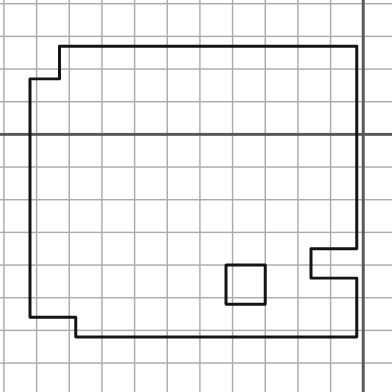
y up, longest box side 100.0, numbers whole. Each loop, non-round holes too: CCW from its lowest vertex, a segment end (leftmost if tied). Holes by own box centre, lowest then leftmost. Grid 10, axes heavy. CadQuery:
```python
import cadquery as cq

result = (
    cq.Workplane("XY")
    .moveTo(-88.0, -62.0)
    .lineTo(-2.0, -62.0)
    .lineTo(-2.0, -44.0)
    .lineTo(-16.0, -44.0)
    .lineTo(-16.0, -35.0)
    .lineTo(-2.0, -35.0)
    .lineTo(-2.0, 27.0)
    .lineTo(-93.0, 27.0)
    .lineTo(-93.0, 17.0)
    .lineTo(-102.0, 17.0)
    .lineTo(-102.0, -56.0)
    .lineTo(-88.0, -56.0)
    .close()
    .moveTo(-42.0, -52.0)
    .lineTo(-30.0, -52.0)
    .lineTo(-30.0, -40.0)
    .lineTo(-42.0, -40.0)
    .close()
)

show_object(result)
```